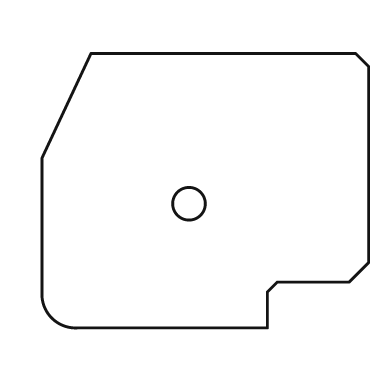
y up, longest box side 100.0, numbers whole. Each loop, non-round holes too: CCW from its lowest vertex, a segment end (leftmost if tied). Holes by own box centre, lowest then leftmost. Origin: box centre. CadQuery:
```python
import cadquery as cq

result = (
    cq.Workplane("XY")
    .moveTo(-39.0, -42.0)
    .lineTo(19.0, -42.0)
    .lineTo(19.0, -31.0)
    .lineTo(22.0, -28.0)
    .lineTo(44.0, -28.0)
    .lineTo(50.0, -22.0)
    .lineTo(50.0, 38.0)
    .lineTo(46.0, 42.0)
    .lineTo(-35.0, 42.0)
    .lineTo(-50.0, 10.0)
    .lineTo(-50.0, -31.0)
    .threePointArc((-47.0, -39.0), (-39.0, -42.0))
    .close()
    .moveTo(-5.0, -4.0)
    .circle(5.0)
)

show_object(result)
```